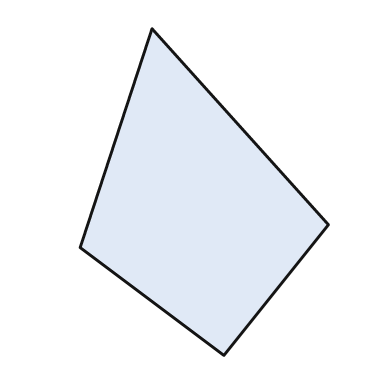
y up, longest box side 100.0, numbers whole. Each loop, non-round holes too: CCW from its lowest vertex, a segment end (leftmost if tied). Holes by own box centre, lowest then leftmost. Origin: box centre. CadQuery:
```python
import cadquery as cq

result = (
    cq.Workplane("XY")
    .moveTo(6.0, -50.0)
    .lineTo(38.0, -10.0)
    .lineTo(-16.0, 50.0)
    .lineTo(-38.0, -17.0)
    .close()
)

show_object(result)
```